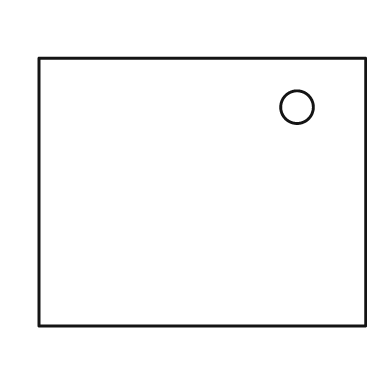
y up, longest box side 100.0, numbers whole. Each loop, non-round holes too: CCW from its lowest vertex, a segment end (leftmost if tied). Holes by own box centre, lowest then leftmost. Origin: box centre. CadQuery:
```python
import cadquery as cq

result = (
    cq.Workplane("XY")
    .moveTo(-50.0, -41.0)
    .lineTo(50.0, -41.0)
    .lineTo(50.0, 41.0)
    .lineTo(-50.0, 41.0)
    .close()
    .moveTo(29.0, 26.0)
    .circle(5.0)
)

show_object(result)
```